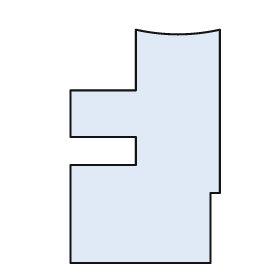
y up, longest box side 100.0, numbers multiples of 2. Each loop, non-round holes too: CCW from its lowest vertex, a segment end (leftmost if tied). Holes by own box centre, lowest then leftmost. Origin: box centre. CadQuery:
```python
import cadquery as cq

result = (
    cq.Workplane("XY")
    .moveTo(-32.0, -50.0)
    .lineTo(28.0, -50.0)
    .lineTo(28.0, -20.0)
    .lineTo(32.0, -20.0)
    .lineTo(32.0, 50.0)
    .threePointArc((14.0, 48.0), (-4.0, 50.0))
    .lineTo(-4.0, 24.0)
    .lineTo(-32.0, 24.0)
    .lineTo(-32.0, 4.0)
    .lineTo(-4.0, 4.0)
    .lineTo(-4.0, -8.0)
    .lineTo(-32.0, -8.0)
    .close()
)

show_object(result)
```